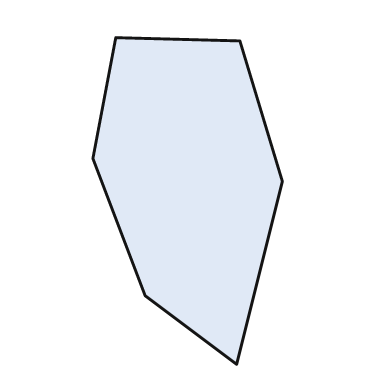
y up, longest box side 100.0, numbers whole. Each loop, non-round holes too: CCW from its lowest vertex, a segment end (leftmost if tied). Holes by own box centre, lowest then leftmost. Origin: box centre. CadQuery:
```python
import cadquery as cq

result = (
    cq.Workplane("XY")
    .moveTo(15.0, -50.0)
    .lineTo(29.0, 6.0)
    .lineTo(16.0, 49.0)
    .lineTo(-22.0, 50.0)
    .lineTo(-29.0, 13.0)
    .lineTo(-13.0, -29.0)
    .close()
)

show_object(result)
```